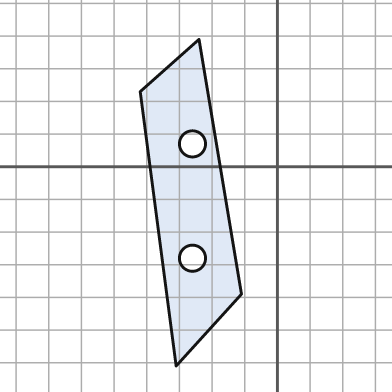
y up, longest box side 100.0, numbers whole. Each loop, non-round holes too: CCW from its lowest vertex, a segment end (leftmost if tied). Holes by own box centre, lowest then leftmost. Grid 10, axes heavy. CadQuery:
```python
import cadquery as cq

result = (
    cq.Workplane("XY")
    .moveTo(-31.0, -61.0)
    .lineTo(-11.0, -39.0)
    .lineTo(-24.0, 39.0)
    .lineTo(-42.0, 23.0)
    .close()
    .moveTo(-26.0, -28.0)
    .circle(4.0)
    .moveTo(-26.0, 7.0)
    .circle(4.0)
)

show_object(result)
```